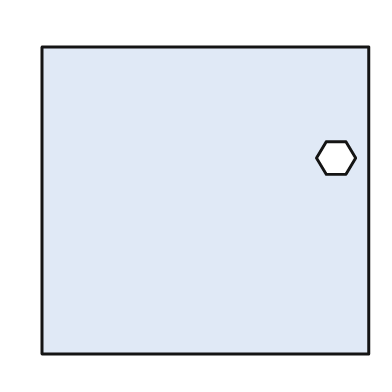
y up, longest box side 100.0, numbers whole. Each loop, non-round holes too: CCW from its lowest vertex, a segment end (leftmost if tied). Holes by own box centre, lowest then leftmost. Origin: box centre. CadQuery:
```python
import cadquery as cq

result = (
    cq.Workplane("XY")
    .moveTo(-50.0, -47.0)
    .lineTo(50.0, -47.0)
    .lineTo(50.0, 47.0)
    .lineTo(-50.0, 47.0)
    .close()
    .moveTo(37.0, 8.0)
    .lineTo(43.0, 8.0)
    .lineTo(46.0, 13.0)
    .lineTo(43.0, 18.0)
    .lineTo(37.0, 18.0)
    .lineTo(34.0, 13.0)
    .close()
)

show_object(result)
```